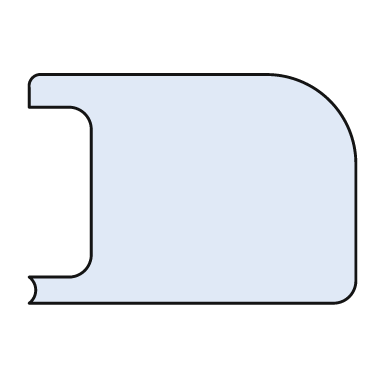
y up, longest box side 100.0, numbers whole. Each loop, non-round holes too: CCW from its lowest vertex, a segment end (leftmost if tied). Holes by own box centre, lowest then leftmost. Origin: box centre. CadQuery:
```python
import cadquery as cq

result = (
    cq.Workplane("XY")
    .moveTo(-50.0, -35.0)
    .lineTo(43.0, -35.0)
    .threePointArc((48.0, -33.0), (50.0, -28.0))
    .lineTo(50.0, 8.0)
    .threePointArc((42.0, 27.0), (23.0, 35.0))
    .lineTo(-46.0, 35.0)
    .threePointArc((-49.0, 34.0), (-50.0, 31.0))
    .lineTo(-50.0, 25.0)
    .lineTo(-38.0, 25.0)
    .threePointArc((-33.0, 23.0), (-31.0, 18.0))
    .lineTo(-31.0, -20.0)
    .threePointArc((-33.0, -25.0), (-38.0, -27.0))
    .lineTo(-50.0, -27.0)
    .threePointArc((-48.0, -31.0), (-50.0, -35.0))
    .close()
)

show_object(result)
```